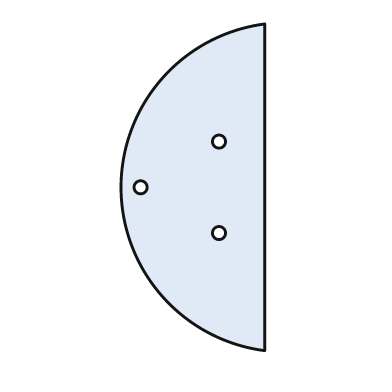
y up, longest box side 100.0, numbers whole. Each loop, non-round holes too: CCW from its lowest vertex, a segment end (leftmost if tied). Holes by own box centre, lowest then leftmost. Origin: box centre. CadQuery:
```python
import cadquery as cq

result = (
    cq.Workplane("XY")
    .moveTo(22.0, -50.0)
    .lineTo(22.0, 50.0)
    .threePointArc((-22.0, 0.0), (22.0, -50.0))
    .close()
    .moveTo(8.0, -14.0)
    .circle(2.0)
    .moveTo(-16.0, 0.0)
    .circle(2.0)
    .moveTo(8.0, 14.0)
    .circle(2.0)
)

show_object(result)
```